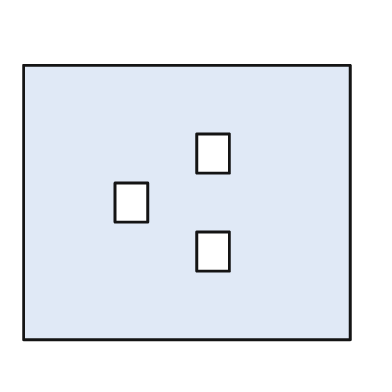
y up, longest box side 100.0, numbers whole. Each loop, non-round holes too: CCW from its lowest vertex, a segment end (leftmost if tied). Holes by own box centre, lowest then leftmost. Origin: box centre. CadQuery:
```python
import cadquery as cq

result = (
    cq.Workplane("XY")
    .moveTo(-50.0, -42.0)
    .lineTo(50.0, -42.0)
    .lineTo(50.0, 42.0)
    .lineTo(-50.0, 42.0)
    .close()
    .moveTo(3.0, -21.0)
    .lineTo(13.0, -21.0)
    .lineTo(13.0, -9.0)
    .lineTo(3.0, -9.0)
    .close()
    .moveTo(-22.0, -6.0)
    .lineTo(-12.0, -6.0)
    .lineTo(-12.0, 6.0)
    .lineTo(-22.0, 6.0)
    .close()
    .moveTo(3.0, 9.0)
    .lineTo(13.0, 9.0)
    .lineTo(13.0, 21.0)
    .lineTo(3.0, 21.0)
    .close()
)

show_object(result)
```